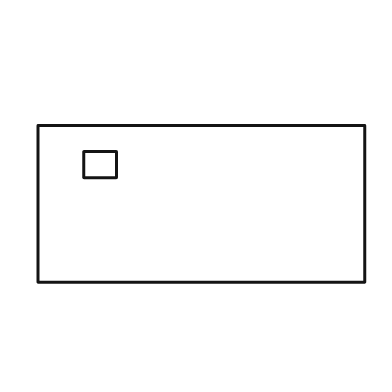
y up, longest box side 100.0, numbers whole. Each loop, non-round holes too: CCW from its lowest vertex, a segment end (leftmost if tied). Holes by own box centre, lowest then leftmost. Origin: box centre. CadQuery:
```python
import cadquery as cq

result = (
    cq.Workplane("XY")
    .moveTo(-50.0, -24.0)
    .lineTo(50.0, -24.0)
    .lineTo(50.0, 24.0)
    .lineTo(-50.0, 24.0)
    .close()
    .moveTo(-36.0, 8.0)
    .lineTo(-26.0, 8.0)
    .lineTo(-26.0, 16.0)
    .lineTo(-36.0, 16.0)
    .close()
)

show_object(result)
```